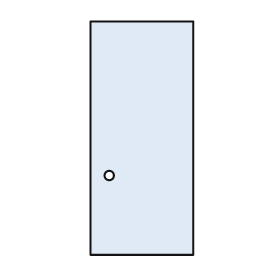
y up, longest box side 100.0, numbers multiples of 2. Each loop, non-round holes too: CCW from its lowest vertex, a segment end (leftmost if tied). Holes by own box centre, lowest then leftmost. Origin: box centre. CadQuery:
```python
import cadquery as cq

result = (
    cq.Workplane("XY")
    .moveTo(-22.0, -50.0)
    .lineTo(22.0, -50.0)
    .lineTo(22.0, 50.0)
    .lineTo(-22.0, 50.0)
    .close()
    .moveTo(-14.0, -16.0)
    .circle(2.0)
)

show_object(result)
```